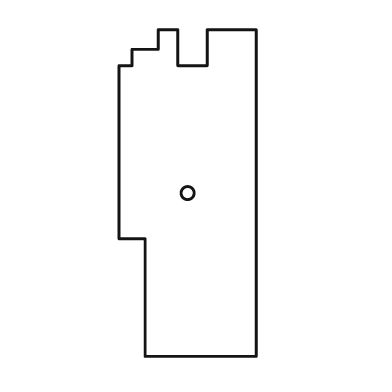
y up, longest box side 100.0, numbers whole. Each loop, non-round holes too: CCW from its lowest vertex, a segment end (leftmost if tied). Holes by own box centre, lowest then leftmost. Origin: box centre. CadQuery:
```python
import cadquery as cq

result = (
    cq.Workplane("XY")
    .moveTo(-13.0, -50.0)
    .lineTo(21.0, -50.0)
    .lineTo(21.0, 50.0)
    .lineTo(6.0, 50.0)
    .lineTo(6.0, 39.0)
    .lineTo(-3.0, 39.0)
    .lineTo(-3.0, 50.0)
    .lineTo(-9.0, 50.0)
    .lineTo(-9.0, 44.0)
    .lineTo(-17.0, 44.0)
    .lineTo(-17.0, 39.0)
    .lineTo(-21.0, 39.0)
    .lineTo(-21.0, -14.0)
    .lineTo(-13.0, -14.0)
    .close()
    .moveTo(0.0, 0.0)
    .circle(2.0)
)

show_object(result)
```